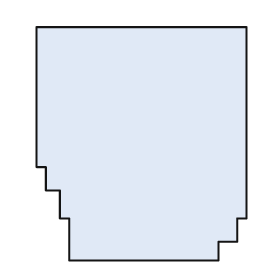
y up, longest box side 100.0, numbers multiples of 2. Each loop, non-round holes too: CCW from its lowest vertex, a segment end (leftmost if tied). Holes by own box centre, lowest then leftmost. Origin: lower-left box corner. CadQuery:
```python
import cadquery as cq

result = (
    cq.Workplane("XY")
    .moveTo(14.0, 0.0)
    .lineTo(78.0, 0.0)
    .lineTo(78.0, 8.0)
    .lineTo(86.0, 8.0)
    .lineTo(86.0, 18.0)
    .lineTo(90.0, 18.0)
    .lineTo(90.0, 100.0)
    .lineTo(0.0, 100.0)
    .lineTo(0.0, 40.0)
    .lineTo(4.0, 40.0)
    .lineTo(4.0, 30.0)
    .lineTo(10.0, 30.0)
    .lineTo(10.0, 18.0)
    .lineTo(14.0, 18.0)
    .close()
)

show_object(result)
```